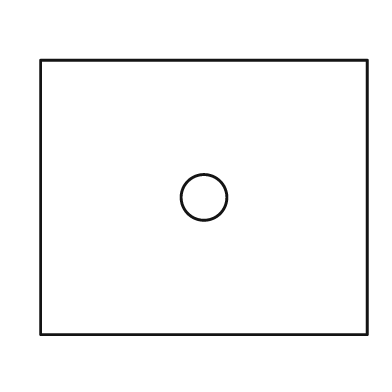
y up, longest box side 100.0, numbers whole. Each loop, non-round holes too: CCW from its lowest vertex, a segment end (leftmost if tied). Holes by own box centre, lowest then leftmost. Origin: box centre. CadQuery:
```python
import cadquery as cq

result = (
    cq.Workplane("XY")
    .moveTo(-50.0, -42.0)
    .lineTo(50.0, -42.0)
    .lineTo(50.0, 42.0)
    .lineTo(-50.0, 42.0)
    .close()
    .moveTo(0.0, 0.0)
    .circle(7.0)
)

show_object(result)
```